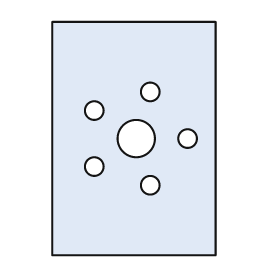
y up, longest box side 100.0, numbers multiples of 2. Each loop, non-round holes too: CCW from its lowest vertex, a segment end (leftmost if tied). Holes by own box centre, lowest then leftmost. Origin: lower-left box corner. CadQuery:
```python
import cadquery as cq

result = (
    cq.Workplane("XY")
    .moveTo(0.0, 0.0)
    .lineTo(70.0, 0.0)
    .lineTo(70.0, 100.0)
    .lineTo(0.0, 100.0)
    .close()
    .moveTo(42.0, 30.0)
    .circle(4.0)
    .moveTo(18.0, 38.0)
    .circle(4.0)
    .moveTo(36.0, 50.0)
    .circle(8.0)
    .moveTo(58.0, 50.0)
    .circle(4.0)
    .moveTo(18.0, 62.0)
    .circle(4.0)
    .moveTo(42.0, 70.0)
    .circle(4.0)
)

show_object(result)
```